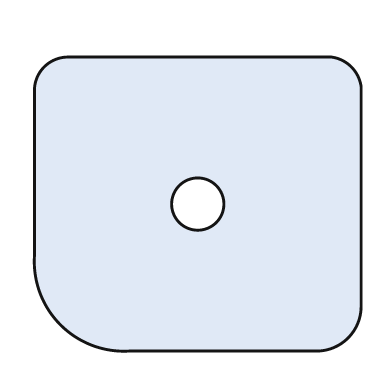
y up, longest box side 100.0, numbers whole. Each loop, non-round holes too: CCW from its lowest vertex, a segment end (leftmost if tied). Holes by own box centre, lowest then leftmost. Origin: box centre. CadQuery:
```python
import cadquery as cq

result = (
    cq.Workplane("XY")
    .moveTo(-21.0, -45.0)
    .lineTo(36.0, -45.0)
    .threePointArc((46.0, -41.0), (50.0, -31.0))
    .lineTo(50.0, 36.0)
    .threePointArc((47.0, 42.0), (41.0, 45.0))
    .lineTo(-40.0, 45.0)
    .threePointArc((-47.0, 42.0), (-50.0, 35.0))
    .lineTo(-50.0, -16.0)
    .threePointArc((-42.0, -37.0), (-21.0, -45.0))
    .close()
    .moveTo(0.0, 0.0)
    .circle(8.0)
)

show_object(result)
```